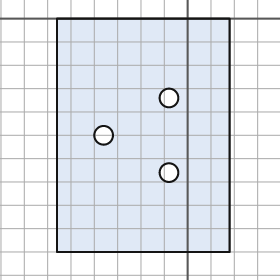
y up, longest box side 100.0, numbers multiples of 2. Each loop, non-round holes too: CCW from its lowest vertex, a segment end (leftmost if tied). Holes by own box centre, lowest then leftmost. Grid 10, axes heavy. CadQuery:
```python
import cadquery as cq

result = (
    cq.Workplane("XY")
    .moveTo(-56.0, -100.0)
    .lineTo(18.0, -100.0)
    .lineTo(18.0, 0.0)
    .lineTo(-56.0, 0.0)
    .close()
    .moveTo(-8.0, -66.0)
    .circle(4.0)
    .moveTo(-36.0, -50.0)
    .circle(4.0)
    .moveTo(-8.0, -34.0)
    .circle(4.0)
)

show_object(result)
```